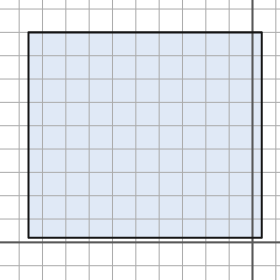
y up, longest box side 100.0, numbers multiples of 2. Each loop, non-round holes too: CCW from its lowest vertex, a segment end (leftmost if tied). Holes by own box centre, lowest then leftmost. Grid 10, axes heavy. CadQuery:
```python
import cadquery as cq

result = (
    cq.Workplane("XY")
    .moveTo(-96.0, 2.0)
    .lineTo(4.0, 2.0)
    .lineTo(4.0, 90.0)
    .lineTo(-96.0, 90.0)
    .close()
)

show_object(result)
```